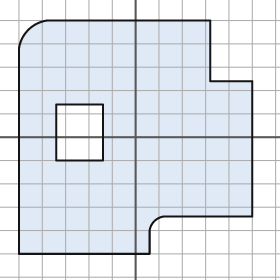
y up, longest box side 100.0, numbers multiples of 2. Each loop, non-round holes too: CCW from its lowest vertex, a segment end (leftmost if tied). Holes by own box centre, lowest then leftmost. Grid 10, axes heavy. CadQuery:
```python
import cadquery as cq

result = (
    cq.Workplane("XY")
    .moveTo(-50.0, -50.0)
    .lineTo(6.0, -50.0)
    .lineTo(6.0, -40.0)
    .threePointArc((8.0, -36.0), (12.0, -34.0))
    .lineTo(50.0, -34.0)
    .lineTo(50.0, 24.0)
    .lineTo(32.0, 24.0)
    .lineTo(32.0, 50.0)
    .lineTo(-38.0, 50.0)
    .threePointArc((-46.0, 46.0), (-50.0, 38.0))
    .close()
    .moveTo(-34.0, -10.0)
    .lineTo(-14.0, -10.0)
    .lineTo(-14.0, 14.0)
    .lineTo(-34.0, 14.0)
    .close()
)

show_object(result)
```